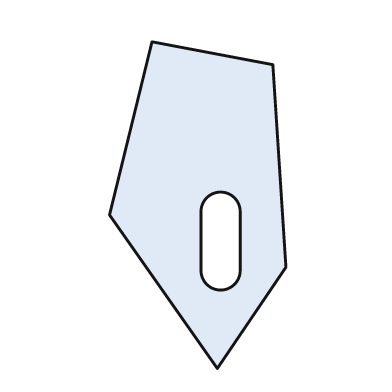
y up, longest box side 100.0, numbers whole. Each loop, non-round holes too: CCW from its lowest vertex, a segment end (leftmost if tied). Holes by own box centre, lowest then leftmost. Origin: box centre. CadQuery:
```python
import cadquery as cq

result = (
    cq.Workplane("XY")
    .moveTo(6.0, -50.0)
    .lineTo(27.0, -19.0)
    .lineTo(23.0, 43.0)
    .lineTo(-14.0, 50.0)
    .lineTo(-27.0, -3.0)
    .close()
    .moveTo(1.0, -20.0)
    .threePointArc((7.0, -26.0), (13.0, -20.0))
    .lineTo(13.0, -2.0)
    .threePointArc((7.0, 4.0), (1.0, -2.0))
    .close()
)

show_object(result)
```